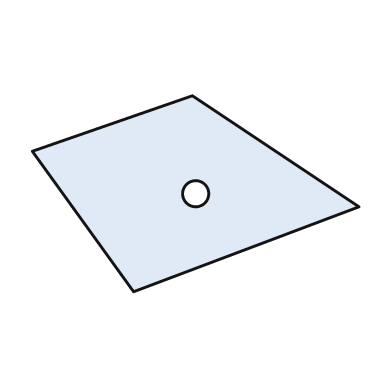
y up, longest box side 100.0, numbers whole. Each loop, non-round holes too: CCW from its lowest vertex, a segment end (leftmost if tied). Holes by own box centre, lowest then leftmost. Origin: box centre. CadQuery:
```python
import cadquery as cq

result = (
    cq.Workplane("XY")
    .moveTo(-19.0, -30.0)
    .lineTo(50.0, -4.0)
    .lineTo(-1.0, 30.0)
    .lineTo(-50.0, 13.0)
    .close()
    .moveTo(0.0, 0.0)
    .circle(4.0)
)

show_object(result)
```